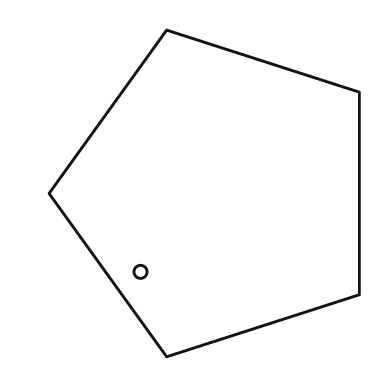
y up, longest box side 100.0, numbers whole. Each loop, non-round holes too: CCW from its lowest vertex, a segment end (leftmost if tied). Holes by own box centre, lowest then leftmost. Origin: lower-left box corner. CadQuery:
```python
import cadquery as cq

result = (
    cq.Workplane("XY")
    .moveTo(36.0, 0.0)
    .lineTo(95.0, 19.0)
    .lineTo(95.0, 81.0)
    .lineTo(36.0, 100.0)
    .lineTo(0.0, 50.0)
    .close()
    .moveTo(28.0, 26.0)
    .circle(2.0)
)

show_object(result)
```